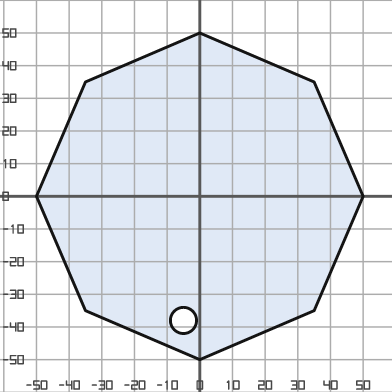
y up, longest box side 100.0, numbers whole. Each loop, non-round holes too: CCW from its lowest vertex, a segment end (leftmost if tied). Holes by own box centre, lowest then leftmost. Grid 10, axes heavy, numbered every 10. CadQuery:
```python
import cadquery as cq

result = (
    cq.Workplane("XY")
    .moveTo(0.0, -50.0)
    .lineTo(35.0, -35.0)
    .lineTo(50.0, 0.0)
    .lineTo(35.0, 35.0)
    .lineTo(0.0, 50.0)
    .lineTo(-35.0, 35.0)
    .lineTo(-50.0, 0.0)
    .lineTo(-35.0, -35.0)
    .close()
    .moveTo(-5.0, -38.0)
    .circle(4.0)
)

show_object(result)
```